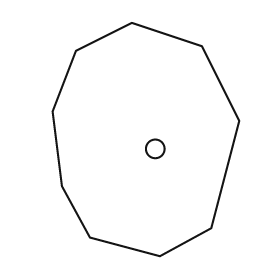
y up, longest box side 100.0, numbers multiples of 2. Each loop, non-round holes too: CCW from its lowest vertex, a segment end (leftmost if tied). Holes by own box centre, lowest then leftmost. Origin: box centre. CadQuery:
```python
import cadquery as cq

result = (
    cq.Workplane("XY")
    .moveTo(6.0, -50.0)
    .lineTo(28.0, -38.0)
    .lineTo(40.0, 8.0)
    .lineTo(24.0, 40.0)
    .lineTo(-6.0, 50.0)
    .lineTo(-30.0, 38.0)
    .lineTo(-40.0, 12.0)
    .lineTo(-36.0, -20.0)
    .lineTo(-24.0, -42.0)
    .close()
    .moveTo(4.0, -4.0)
    .circle(4.0)
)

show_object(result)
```